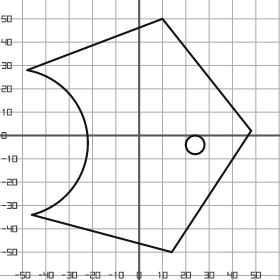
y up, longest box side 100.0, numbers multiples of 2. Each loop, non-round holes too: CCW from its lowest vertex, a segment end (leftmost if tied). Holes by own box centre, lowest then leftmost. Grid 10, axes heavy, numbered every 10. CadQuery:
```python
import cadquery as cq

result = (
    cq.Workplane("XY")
    .moveTo(14.0, -50.0)
    .lineTo(48.0, 2.0)
    .lineTo(10.0, 50.0)
    .lineTo(-48.0, 28.0)
    .threePointArc((-22.0, -2.0), (-46.0, -34.0))
    .close()
    .moveTo(24.0, -4.0)
    .circle(4.0)
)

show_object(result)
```